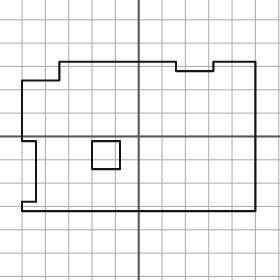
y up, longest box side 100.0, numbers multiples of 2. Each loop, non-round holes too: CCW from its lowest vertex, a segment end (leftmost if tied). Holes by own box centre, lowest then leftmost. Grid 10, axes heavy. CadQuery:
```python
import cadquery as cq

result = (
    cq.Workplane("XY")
    .moveTo(-50.0, -32.0)
    .lineTo(50.0, -32.0)
    .lineTo(50.0, 32.0)
    .lineTo(32.0, 32.0)
    .lineTo(32.0, 28.0)
    .lineTo(16.0, 28.0)
    .lineTo(16.0, 32.0)
    .lineTo(-34.0, 32.0)
    .lineTo(-34.0, 24.0)
    .lineTo(-50.0, 24.0)
    .lineTo(-50.0, -2.0)
    .lineTo(-44.0, -2.0)
    .lineTo(-44.0, -28.0)
    .lineTo(-50.0, -28.0)
    .close()
    .moveTo(-20.0, -14.0)
    .lineTo(-8.0, -14.0)
    .lineTo(-8.0, -2.0)
    .lineTo(-20.0, -2.0)
    .close()
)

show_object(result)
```